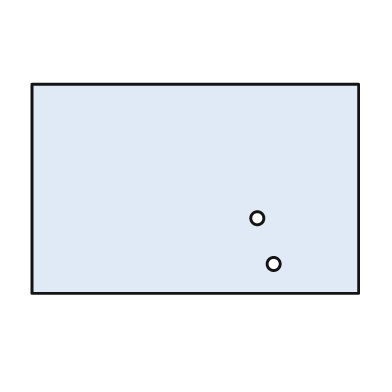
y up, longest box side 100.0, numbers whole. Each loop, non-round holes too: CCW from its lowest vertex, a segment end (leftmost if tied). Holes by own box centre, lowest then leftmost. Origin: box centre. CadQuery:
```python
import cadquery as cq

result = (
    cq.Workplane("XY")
    .moveTo(-50.0, -32.0)
    .lineTo(50.0, -32.0)
    .lineTo(50.0, 32.0)
    .lineTo(-50.0, 32.0)
    .close()
    .moveTo(24.0, -23.0)
    .circle(2.0)
    .moveTo(19.0, -9.0)
    .circle(2.0)
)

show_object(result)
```